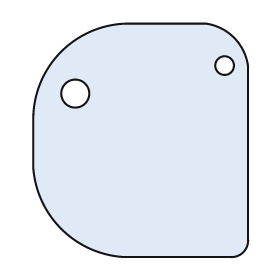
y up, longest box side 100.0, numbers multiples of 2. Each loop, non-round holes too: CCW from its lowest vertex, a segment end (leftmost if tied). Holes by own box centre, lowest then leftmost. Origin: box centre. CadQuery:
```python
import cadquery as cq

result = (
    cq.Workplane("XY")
    .moveTo(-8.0, -50.0)
    .lineTo(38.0, -50.0)
    .threePointArc((44.0, -48.0), (46.0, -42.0))
    .lineTo(46.0, 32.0)
    .threePointArc((40.0, 44.0), (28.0, 50.0))
    .lineTo(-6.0, 50.0)
    .threePointArc((-34.0, 38.0), (-46.0, 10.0))
    .lineTo(-46.0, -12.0)
    .threePointArc((-34.0, -38.0), (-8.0, -50.0))
    .close()
    .moveTo(-28.0, 20.0)
    .circle(6.0)
    .moveTo(36.0, 32.0)
    .circle(4.0)
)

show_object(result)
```